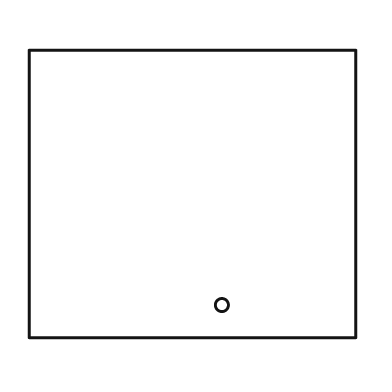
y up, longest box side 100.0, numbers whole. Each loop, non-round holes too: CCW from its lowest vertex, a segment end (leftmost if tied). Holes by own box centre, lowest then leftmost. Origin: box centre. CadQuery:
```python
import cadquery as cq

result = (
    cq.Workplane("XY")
    .moveTo(-50.0, -44.0)
    .lineTo(50.0, -44.0)
    .lineTo(50.0, 44.0)
    .lineTo(-50.0, 44.0)
    .close()
    .moveTo(9.0, -34.0)
    .circle(2.0)
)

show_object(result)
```